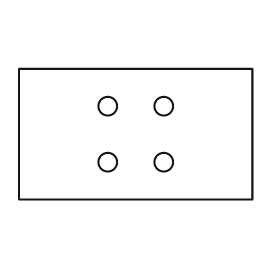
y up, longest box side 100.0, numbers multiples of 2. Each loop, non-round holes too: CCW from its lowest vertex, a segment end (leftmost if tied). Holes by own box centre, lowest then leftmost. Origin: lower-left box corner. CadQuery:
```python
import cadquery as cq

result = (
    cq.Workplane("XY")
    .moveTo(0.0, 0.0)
    .lineTo(100.0, 0.0)
    .lineTo(100.0, 56.0)
    .lineTo(0.0, 56.0)
    .close()
    .moveTo(38.0, 16.0)
    .circle(4.0)
    .moveTo(62.0, 16.0)
    .circle(4.0)
    .moveTo(38.0, 40.0)
    .circle(4.0)
    .moveTo(62.0, 40.0)
    .circle(4.0)
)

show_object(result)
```